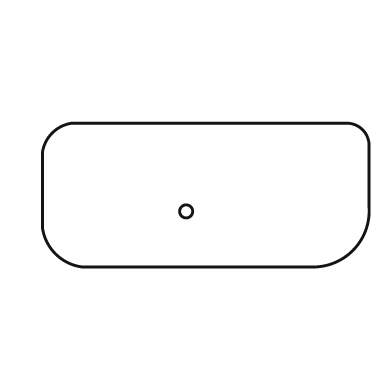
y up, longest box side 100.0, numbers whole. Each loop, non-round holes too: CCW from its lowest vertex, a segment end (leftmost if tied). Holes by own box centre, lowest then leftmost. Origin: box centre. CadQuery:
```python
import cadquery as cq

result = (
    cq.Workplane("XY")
    .moveTo(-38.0, -22.0)
    .lineTo(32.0, -22.0)
    .threePointArc((45.0, -17.0), (50.0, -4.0))
    .lineTo(50.0, 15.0)
    .threePointArc((48.0, 20.0), (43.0, 22.0))
    .lineTo(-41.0, 22.0)
    .threePointArc((-47.0, 19.0), (-50.0, 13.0))
    .lineTo(-50.0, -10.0)
    .threePointArc((-46.0, -18.0), (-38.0, -22.0))
    .close()
    .moveTo(-6.0, -5.0)
    .circle(2.0)
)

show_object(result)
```